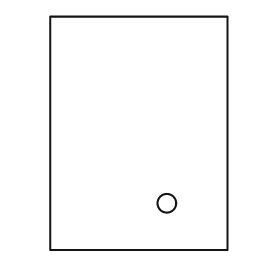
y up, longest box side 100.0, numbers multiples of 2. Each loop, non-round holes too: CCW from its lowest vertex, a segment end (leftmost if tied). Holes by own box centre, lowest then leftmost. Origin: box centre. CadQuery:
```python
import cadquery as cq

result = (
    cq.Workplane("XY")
    .moveTo(-38.0, -50.0)
    .lineTo(38.0, -50.0)
    .lineTo(38.0, 50.0)
    .lineTo(-38.0, 50.0)
    .close()
    .moveTo(12.0, -30.0)
    .circle(4.0)
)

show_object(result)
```